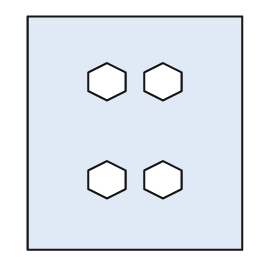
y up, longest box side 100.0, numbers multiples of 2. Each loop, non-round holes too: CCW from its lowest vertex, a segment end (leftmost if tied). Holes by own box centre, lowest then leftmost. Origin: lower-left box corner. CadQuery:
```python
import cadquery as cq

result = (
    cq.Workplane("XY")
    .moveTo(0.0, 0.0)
    .lineTo(92.0, 0.0)
    .lineTo(92.0, 100.0)
    .lineTo(0.0, 100.0)
    .close()
    .moveTo(34.0, 22.0)
    .lineTo(42.0, 26.0)
    .lineTo(42.0, 34.0)
    .lineTo(34.0, 38.0)
    .lineTo(26.0, 34.0)
    .lineTo(26.0, 26.0)
    .close()
    .moveTo(58.0, 22.0)
    .lineTo(66.0, 26.0)
    .lineTo(66.0, 34.0)
    .lineTo(58.0, 38.0)
    .lineTo(50.0, 34.0)
    .lineTo(50.0, 26.0)
    .close()
    .moveTo(34.0, 64.0)
    .lineTo(42.0, 68.0)
    .lineTo(42.0, 76.0)
    .lineTo(34.0, 80.0)
    .lineTo(26.0, 76.0)
    .lineTo(26.0, 68.0)
    .close()
    .moveTo(58.0, 64.0)
    .lineTo(66.0, 68.0)
    .lineTo(66.0, 76.0)
    .lineTo(58.0, 80.0)
    .lineTo(50.0, 76.0)
    .lineTo(50.0, 68.0)
    .close()
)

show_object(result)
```